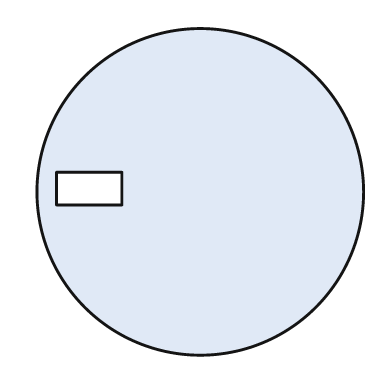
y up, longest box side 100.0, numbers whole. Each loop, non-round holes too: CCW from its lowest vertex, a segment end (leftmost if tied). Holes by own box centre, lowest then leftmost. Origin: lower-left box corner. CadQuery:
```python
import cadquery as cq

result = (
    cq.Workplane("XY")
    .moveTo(50.0, 50.0)
    .circle(50.0)
    .moveTo(6.0, 46.0)
    .lineTo(26.0, 46.0)
    .lineTo(26.0, 56.0)
    .lineTo(6.0, 56.0)
    .close()
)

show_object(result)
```